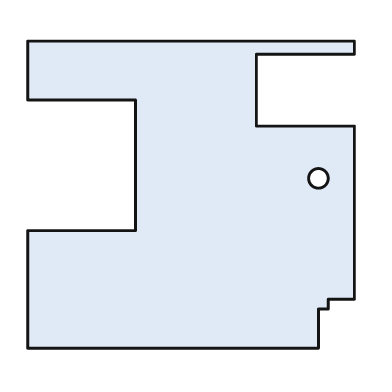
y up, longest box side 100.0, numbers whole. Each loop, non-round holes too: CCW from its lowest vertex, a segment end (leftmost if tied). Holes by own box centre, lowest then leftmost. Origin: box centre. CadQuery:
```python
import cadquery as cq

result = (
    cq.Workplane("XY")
    .moveTo(-50.0, -47.0)
    .lineTo(39.0, -47.0)
    .lineTo(39.0, -35.0)
    .lineTo(42.0, -35.0)
    .lineTo(42.0, -32.0)
    .lineTo(50.0, -32.0)
    .lineTo(50.0, 21.0)
    .lineTo(20.0, 21.0)
    .lineTo(20.0, 43.0)
    .lineTo(50.0, 43.0)
    .lineTo(50.0, 47.0)
    .lineTo(-50.0, 47.0)
    .lineTo(-50.0, 29.0)
    .lineTo(-17.0, 29.0)
    .lineTo(-17.0, -11.0)
    .lineTo(-50.0, -11.0)
    .close()
    .moveTo(39.0, 5.0)
    .circle(3.0)
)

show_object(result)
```